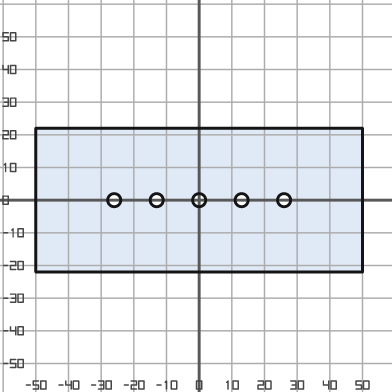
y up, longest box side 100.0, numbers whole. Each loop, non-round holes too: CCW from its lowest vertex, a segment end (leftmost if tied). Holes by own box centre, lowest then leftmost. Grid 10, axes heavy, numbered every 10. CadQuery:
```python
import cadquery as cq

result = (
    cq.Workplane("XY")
    .moveTo(-50.0, -22.0)
    .lineTo(50.0, -22.0)
    .lineTo(50.0, 22.0)
    .lineTo(-50.0, 22.0)
    .close()
    .moveTo(-26.0, 0.0)
    .circle(2.0)
    .moveTo(-13.0, 0.0)
    .circle(2.0)
    .moveTo(0.0, 0.0)
    .circle(2.0)
    .moveTo(13.0, 0.0)
    .circle(2.0)
    .moveTo(26.0, 0.0)
    .circle(2.0)
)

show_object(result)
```